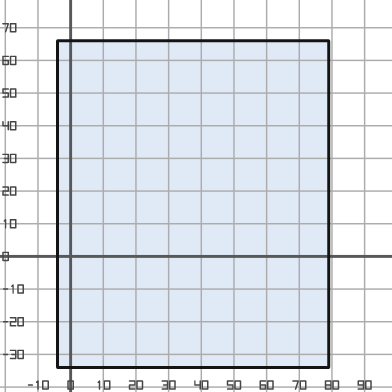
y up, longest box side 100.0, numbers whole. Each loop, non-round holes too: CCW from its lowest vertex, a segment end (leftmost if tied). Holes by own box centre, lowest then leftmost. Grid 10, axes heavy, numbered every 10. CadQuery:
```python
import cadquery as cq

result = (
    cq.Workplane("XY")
    .moveTo(-4.0, -34.0)
    .lineTo(79.0, -34.0)
    .lineTo(79.0, 66.0)
    .lineTo(-4.0, 66.0)
    .close()
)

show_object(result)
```